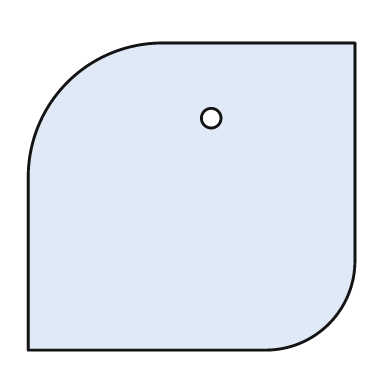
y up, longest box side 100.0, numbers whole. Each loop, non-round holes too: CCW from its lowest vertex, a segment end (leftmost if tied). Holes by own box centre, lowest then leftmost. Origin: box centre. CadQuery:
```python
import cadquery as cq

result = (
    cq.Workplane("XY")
    .moveTo(-50.0, -47.0)
    .lineTo(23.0, -47.0)
    .threePointArc((42.0, -39.0), (50.0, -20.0))
    .lineTo(50.0, 47.0)
    .lineTo(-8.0, 47.0)
    .threePointArc((-38.0, 35.0), (-50.0, 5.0))
    .close()
    .moveTo(6.0, 24.0)
    .circle(3.0)
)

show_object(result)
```